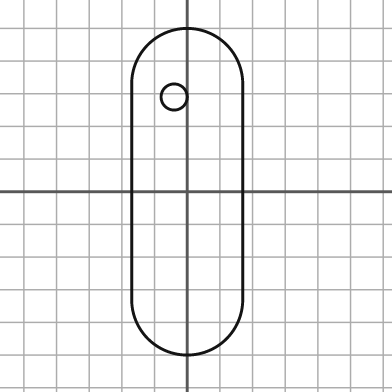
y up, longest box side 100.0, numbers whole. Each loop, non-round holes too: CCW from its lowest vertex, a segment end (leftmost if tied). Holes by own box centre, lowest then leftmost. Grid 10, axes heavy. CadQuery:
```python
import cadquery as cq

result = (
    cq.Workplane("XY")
    .moveTo(-17.0, -33.0)
    .threePointArc((0.0, -50.0), (17.0, -33.0))
    .lineTo(17.0, 33.0)
    .threePointArc((0.0, 50.0), (-17.0, 33.0))
    .close()
    .moveTo(-4.0, 29.0)
    .circle(4.0)
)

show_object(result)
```